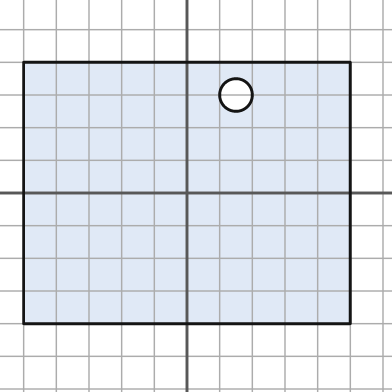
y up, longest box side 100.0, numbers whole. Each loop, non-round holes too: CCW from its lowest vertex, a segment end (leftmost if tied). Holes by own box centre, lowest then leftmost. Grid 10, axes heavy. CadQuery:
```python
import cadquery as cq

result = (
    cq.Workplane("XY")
    .moveTo(-50.0, -40.0)
    .lineTo(50.0, -40.0)
    .lineTo(50.0, 40.0)
    .lineTo(-50.0, 40.0)
    .close()
    .moveTo(15.0, 30.0)
    .circle(5.0)
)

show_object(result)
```